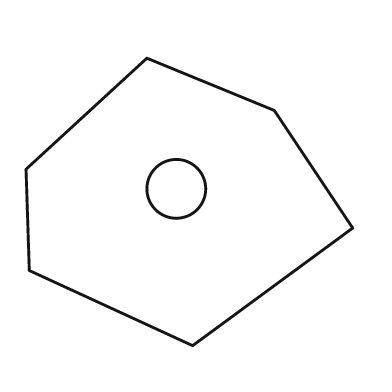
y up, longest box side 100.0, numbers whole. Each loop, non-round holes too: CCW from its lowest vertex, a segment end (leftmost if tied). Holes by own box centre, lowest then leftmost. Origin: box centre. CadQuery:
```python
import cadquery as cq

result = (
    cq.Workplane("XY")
    .moveTo(1.0, -44.0)
    .lineTo(50.0, -8.0)
    .lineTo(26.0, 28.0)
    .lineTo(-13.0, 44.0)
    .lineTo(-50.0, 10.0)
    .lineTo(-49.0, -21.0)
    .close()
    .moveTo(-4.0, 4.0)
    .circle(9.0)
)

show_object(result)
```